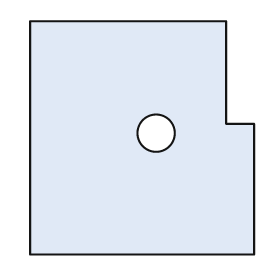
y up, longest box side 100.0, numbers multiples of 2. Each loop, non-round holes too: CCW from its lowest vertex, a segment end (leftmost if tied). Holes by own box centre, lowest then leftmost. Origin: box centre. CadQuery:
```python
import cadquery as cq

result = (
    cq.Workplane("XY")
    .moveTo(-48.0, -50.0)
    .lineTo(48.0, -50.0)
    .lineTo(48.0, 6.0)
    .lineTo(36.0, 6.0)
    .lineTo(36.0, 50.0)
    .lineTo(-48.0, 50.0)
    .close()
    .moveTo(6.0, 2.0)
    .circle(8.0)
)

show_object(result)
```